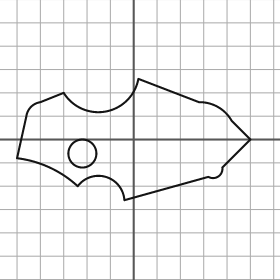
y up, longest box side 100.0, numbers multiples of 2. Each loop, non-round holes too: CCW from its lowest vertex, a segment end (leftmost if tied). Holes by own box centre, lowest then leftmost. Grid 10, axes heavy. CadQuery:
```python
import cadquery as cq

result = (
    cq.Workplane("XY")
    .moveTo(-4.0, -26.0)
    .lineTo(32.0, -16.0)
    .threePointArc((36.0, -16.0), (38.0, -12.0))
    .lineTo(50.0, 0.0)
    .lineTo(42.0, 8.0)
    .threePointArc((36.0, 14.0), (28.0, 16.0))
    .lineTo(2.0, 26.0)
    .threePointArc((-12.0, 12.0), (-30.0, 20.0))
    .lineTo(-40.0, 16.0)
    .threePointArc((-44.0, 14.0), (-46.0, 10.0))
    .lineTo(-50.0, -8.0)
    .threePointArc((-36.0, -12.0), (-24.0, -20.0))
    .threePointArc((-12.0, -16.0), (-4.0, -26.0))
    .close()
    .moveTo(-22.0, -6.0)
    .circle(6.0)
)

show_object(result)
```